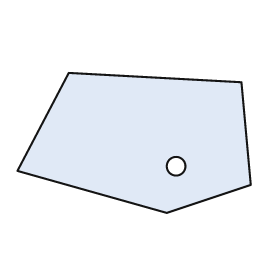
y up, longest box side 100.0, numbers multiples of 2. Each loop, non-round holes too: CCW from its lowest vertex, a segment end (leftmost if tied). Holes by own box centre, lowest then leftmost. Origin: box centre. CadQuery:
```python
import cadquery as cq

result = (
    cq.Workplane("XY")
    .moveTo(14.0, -30.0)
    .lineTo(50.0, -18.0)
    .lineTo(46.0, 26.0)
    .lineTo(-28.0, 30.0)
    .lineTo(-50.0, -12.0)
    .close()
    .moveTo(18.0, -10.0)
    .circle(4.0)
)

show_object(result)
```